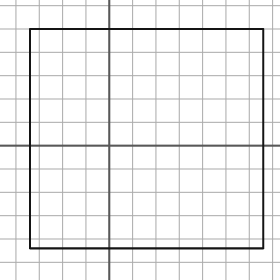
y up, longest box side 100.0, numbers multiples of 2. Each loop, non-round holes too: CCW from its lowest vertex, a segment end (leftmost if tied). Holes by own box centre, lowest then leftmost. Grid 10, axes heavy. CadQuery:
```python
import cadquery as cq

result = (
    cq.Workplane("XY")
    .moveTo(-34.0, -44.0)
    .lineTo(66.0, -44.0)
    .lineTo(66.0, 50.0)
    .lineTo(-34.0, 50.0)
    .close()
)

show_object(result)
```